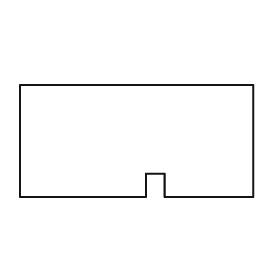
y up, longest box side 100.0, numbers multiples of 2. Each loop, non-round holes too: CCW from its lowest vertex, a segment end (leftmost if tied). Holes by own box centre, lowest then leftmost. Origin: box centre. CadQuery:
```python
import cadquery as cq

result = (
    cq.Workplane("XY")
    .moveTo(-50.0, -24.0)
    .lineTo(4.0, -24.0)
    .lineTo(4.0, -14.0)
    .lineTo(12.0, -14.0)
    .lineTo(12.0, -24.0)
    .lineTo(50.0, -24.0)
    .lineTo(50.0, 24.0)
    .lineTo(-50.0, 24.0)
    .close()
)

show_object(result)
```